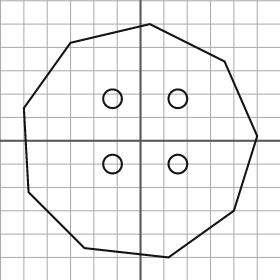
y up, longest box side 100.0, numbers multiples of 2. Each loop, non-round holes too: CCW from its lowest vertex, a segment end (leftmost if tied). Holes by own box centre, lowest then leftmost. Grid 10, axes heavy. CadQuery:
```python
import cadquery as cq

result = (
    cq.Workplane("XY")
    .moveTo(12.0, -50.0)
    .lineTo(40.0, -30.0)
    .lineTo(50.0, 2.0)
    .lineTo(36.0, 34.0)
    .lineTo(4.0, 50.0)
    .lineTo(-30.0, 42.0)
    .lineTo(-50.0, 14.0)
    .lineTo(-48.0, -22.0)
    .lineTo(-24.0, -46.0)
    .close()
    .moveTo(-12.0, -10.0)
    .circle(4.0)
    .moveTo(16.0, -10.0)
    .circle(4.0)
    .moveTo(-12.0, 18.0)
    .circle(4.0)
    .moveTo(16.0, 18.0)
    .circle(4.0)
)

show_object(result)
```